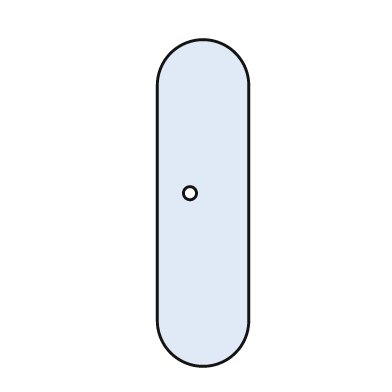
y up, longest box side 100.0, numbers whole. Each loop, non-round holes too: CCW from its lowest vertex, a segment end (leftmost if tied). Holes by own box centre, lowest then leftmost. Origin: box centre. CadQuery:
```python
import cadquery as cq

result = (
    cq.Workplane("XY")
    .moveTo(-14.0, -36.0)
    .threePointArc((0.0, -50.0), (14.0, -36.0))
    .lineTo(14.0, 36.0)
    .threePointArc((0.0, 50.0), (-14.0, 36.0))
    .close()
    .moveTo(-4.0, 3.0)
    .circle(2.0)
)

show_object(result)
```